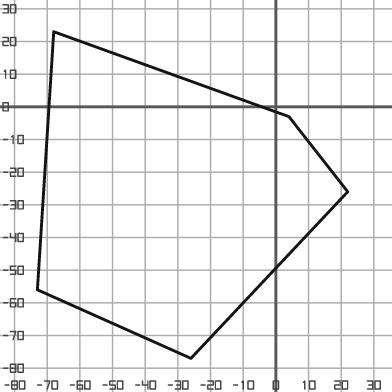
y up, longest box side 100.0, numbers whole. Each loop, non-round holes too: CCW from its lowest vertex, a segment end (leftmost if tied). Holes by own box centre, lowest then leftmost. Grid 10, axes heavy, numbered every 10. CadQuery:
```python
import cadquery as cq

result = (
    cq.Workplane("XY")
    .moveTo(-26.0, -77.0)
    .lineTo(22.0, -26.0)
    .lineTo(4.0, -3.0)
    .lineTo(-68.0, 23.0)
    .lineTo(-73.0, -56.0)
    .close()
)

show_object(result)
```